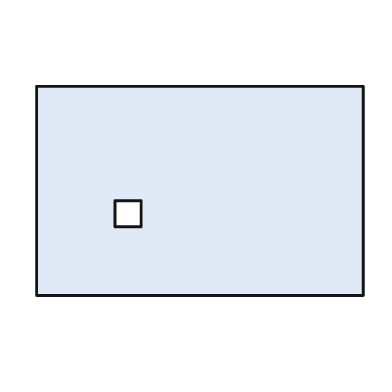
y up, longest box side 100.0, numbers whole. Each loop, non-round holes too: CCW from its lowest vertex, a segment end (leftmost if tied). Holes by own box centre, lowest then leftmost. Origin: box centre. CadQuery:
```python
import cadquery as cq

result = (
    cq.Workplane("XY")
    .moveTo(-50.0, -32.0)
    .lineTo(50.0, -32.0)
    .lineTo(50.0, 32.0)
    .lineTo(-50.0, 32.0)
    .close()
    .moveTo(-26.0, -11.0)
    .lineTo(-18.0, -11.0)
    .lineTo(-18.0, -3.0)
    .lineTo(-26.0, -3.0)
    .close()
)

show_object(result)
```